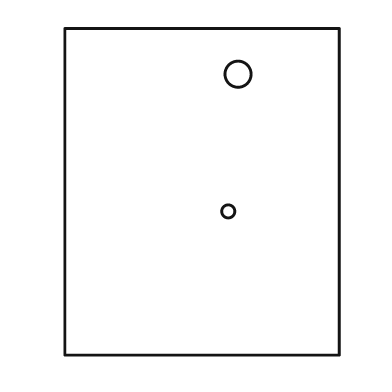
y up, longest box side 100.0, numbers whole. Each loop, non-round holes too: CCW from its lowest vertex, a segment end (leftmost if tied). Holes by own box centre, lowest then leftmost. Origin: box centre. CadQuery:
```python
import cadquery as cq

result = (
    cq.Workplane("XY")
    .moveTo(-42.0, -50.0)
    .lineTo(42.0, -50.0)
    .lineTo(42.0, 50.0)
    .lineTo(-42.0, 50.0)
    .close()
    .moveTo(8.0, -6.0)
    .circle(2.0)
    .moveTo(11.0, 36.0)
    .circle(4.0)
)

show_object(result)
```